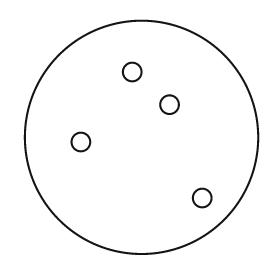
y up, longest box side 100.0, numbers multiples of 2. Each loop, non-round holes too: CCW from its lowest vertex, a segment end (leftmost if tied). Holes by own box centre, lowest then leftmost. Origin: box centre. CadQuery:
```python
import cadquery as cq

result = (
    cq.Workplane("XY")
    .moveTo(0.0, 0.0)
    .circle(50.0)
    .moveTo(26.0, -26.0)
    .circle(4.0)
    .moveTo(-26.0, -2.0)
    .circle(4.0)
    .moveTo(12.0, 14.0)
    .circle(4.0)
    .moveTo(-4.0, 28.0)
    .circle(4.0)
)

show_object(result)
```